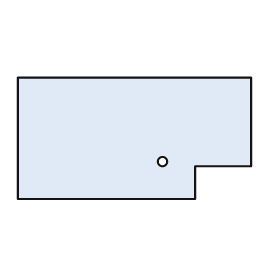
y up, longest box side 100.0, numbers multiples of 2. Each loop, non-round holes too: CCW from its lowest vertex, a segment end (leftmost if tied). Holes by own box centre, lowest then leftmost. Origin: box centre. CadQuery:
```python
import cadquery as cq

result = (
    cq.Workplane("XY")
    .moveTo(-50.0, -26.0)
    .lineTo(26.0, -26.0)
    .lineTo(26.0, -12.0)
    .lineTo(50.0, -12.0)
    .lineTo(50.0, 26.0)
    .lineTo(-50.0, 26.0)
    .close()
    .moveTo(12.0, -10.0)
    .circle(2.0)
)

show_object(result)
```